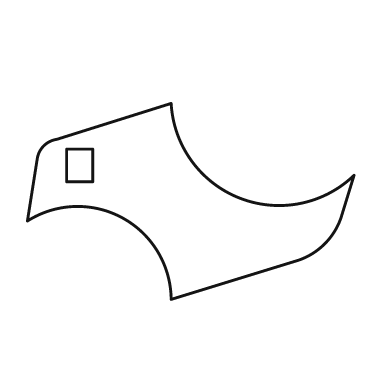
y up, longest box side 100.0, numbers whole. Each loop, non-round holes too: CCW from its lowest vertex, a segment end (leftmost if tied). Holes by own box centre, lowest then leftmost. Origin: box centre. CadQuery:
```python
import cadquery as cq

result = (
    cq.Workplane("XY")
    .moveTo(-6.0, -30.0)
    .lineTo(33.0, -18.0)
    .threePointArc((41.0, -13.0), (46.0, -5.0))
    .lineTo(50.0, 8.0)
    .threePointArc((15.0, 1.0), (-6.0, 30.0))
    .lineTo(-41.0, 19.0)
    .threePointArc((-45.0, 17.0), (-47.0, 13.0))
    .lineTo(-50.0, -6.0)
    .threePointArc((-21.0, -5.0), (-6.0, -30.0))
    .close()
    .moveTo(-38.0, 6.0)
    .lineTo(-30.0, 6.0)
    .lineTo(-30.0, 16.0)
    .lineTo(-38.0, 16.0)
    .close()
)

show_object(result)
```